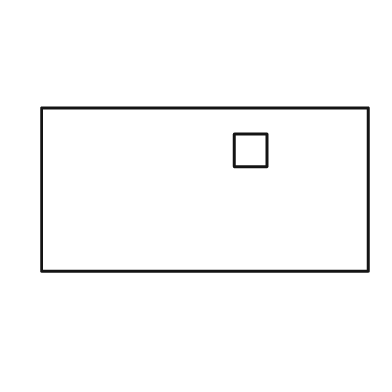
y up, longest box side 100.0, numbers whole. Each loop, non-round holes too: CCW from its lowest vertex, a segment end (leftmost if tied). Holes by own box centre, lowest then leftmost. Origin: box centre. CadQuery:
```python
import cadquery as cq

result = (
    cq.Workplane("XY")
    .moveTo(-50.0, -25.0)
    .lineTo(50.0, -25.0)
    .lineTo(50.0, 25.0)
    .lineTo(-50.0, 25.0)
    .close()
    .moveTo(9.0, 7.0)
    .lineTo(19.0, 7.0)
    .lineTo(19.0, 17.0)
    .lineTo(9.0, 17.0)
    .close()
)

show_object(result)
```